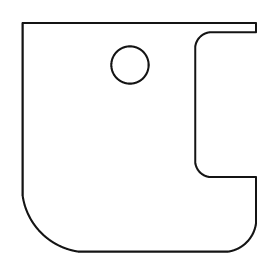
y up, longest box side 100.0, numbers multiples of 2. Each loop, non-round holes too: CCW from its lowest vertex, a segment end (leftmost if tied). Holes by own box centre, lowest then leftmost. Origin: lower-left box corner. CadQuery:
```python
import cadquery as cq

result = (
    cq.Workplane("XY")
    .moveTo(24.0, 0.0)
    .lineTo(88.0, 0.0)
    .threePointArc((96.0, 4.0), (100.0, 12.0))
    .lineTo(100.0, 32.0)
    .lineTo(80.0, 32.0)
    .threePointArc((76.0, 34.0), (74.0, 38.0))
    .lineTo(74.0, 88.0)
    .threePointArc((76.0, 92.0), (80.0, 94.0))
    .lineTo(100.0, 94.0)
    .lineTo(100.0, 98.0)
    .lineTo(0.0, 98.0)
    .lineTo(0.0, 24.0)
    .threePointArc((8.0, 8.0), (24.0, 0.0))
    .close()
    .moveTo(46.0, 80.0)
    .circle(8.0)
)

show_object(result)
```